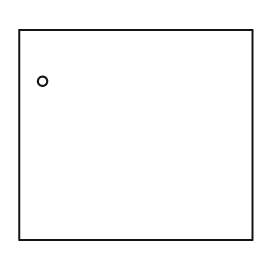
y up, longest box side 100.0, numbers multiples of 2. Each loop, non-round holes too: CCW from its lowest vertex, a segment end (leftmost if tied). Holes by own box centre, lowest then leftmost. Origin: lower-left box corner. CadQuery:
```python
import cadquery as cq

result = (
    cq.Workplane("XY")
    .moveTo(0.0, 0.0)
    .lineTo(100.0, 0.0)
    .lineTo(100.0, 90.0)
    .lineTo(0.0, 90.0)
    .close()
    .moveTo(10.0, 68.0)
    .circle(2.0)
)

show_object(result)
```